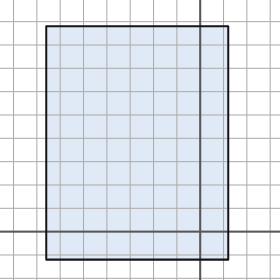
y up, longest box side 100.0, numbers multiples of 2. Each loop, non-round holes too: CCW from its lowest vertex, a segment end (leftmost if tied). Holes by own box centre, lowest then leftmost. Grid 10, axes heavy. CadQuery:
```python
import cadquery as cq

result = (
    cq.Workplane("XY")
    .moveTo(-66.0, -12.0)
    .lineTo(12.0, -12.0)
    .lineTo(12.0, 88.0)
    .lineTo(-66.0, 88.0)
    .close()
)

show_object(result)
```